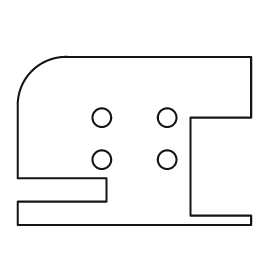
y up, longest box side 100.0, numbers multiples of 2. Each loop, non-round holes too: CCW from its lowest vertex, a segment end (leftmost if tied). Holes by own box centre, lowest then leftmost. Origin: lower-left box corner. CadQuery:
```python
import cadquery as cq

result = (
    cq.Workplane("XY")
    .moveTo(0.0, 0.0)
    .lineTo(100.0, 0.0)
    .lineTo(100.0, 4.0)
    .lineTo(74.0, 4.0)
    .lineTo(74.0, 46.0)
    .lineTo(100.0, 46.0)
    .lineTo(100.0, 72.0)
    .lineTo(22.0, 72.0)
    .threePointArc((6.0, 66.0), (0.0, 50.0))
    .lineTo(0.0, 20.0)
    .lineTo(38.0, 20.0)
    .lineTo(38.0, 10.0)
    .lineTo(0.0, 10.0)
    .close()
    .moveTo(36.0, 28.0)
    .circle(4.0)
    .moveTo(64.0, 28.0)
    .circle(4.0)
    .moveTo(36.0, 46.0)
    .circle(4.0)
    .moveTo(64.0, 46.0)
    .circle(4.0)
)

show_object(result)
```